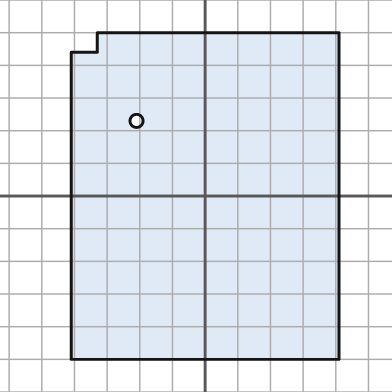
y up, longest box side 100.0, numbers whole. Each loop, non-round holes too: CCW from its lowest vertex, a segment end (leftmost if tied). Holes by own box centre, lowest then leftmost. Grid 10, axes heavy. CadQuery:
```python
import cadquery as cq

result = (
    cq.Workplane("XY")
    .moveTo(-41.0, -50.0)
    .lineTo(41.0, -50.0)
    .lineTo(41.0, 50.0)
    .lineTo(-33.0, 50.0)
    .lineTo(-33.0, 44.0)
    .lineTo(-41.0, 44.0)
    .close()
    .moveTo(-21.0, 23.0)
    .circle(2.0)
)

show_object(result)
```